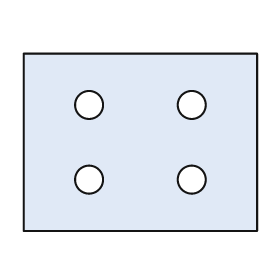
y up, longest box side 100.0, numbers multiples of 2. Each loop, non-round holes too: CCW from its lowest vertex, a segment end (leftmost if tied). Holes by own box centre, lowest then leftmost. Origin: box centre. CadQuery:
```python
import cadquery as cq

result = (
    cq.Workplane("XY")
    .moveTo(-50.0, -38.0)
    .lineTo(50.0, -38.0)
    .lineTo(50.0, 38.0)
    .lineTo(-50.0, 38.0)
    .close()
    .moveTo(-22.0, -16.0)
    .circle(6.0)
    .moveTo(22.0, -16.0)
    .circle(6.0)
    .moveTo(-22.0, 16.0)
    .circle(6.0)
    .moveTo(22.0, 16.0)
    .circle(6.0)
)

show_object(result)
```